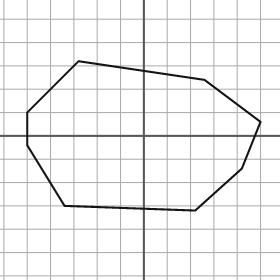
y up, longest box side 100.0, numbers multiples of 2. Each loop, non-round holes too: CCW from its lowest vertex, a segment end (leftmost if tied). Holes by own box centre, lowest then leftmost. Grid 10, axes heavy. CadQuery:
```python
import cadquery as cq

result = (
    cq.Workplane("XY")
    .moveTo(22.0, -32.0)
    .lineTo(42.0, -14.0)
    .lineTo(50.0, 6.0)
    .lineTo(26.0, 24.0)
    .lineTo(-28.0, 32.0)
    .lineTo(-50.0, 10.0)
    .lineTo(-50.0, -4.0)
    .lineTo(-34.0, -30.0)
    .close()
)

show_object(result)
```